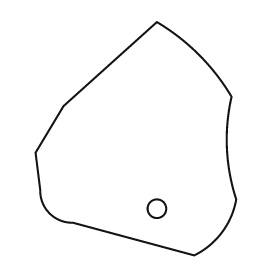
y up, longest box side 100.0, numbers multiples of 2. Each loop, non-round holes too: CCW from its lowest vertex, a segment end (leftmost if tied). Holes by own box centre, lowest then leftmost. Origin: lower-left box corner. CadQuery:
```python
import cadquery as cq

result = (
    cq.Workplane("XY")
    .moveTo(68.0, 0.0)
    .threePointArc((80.0, 10.0), (86.0, 24.0))
    .threePointArc((82.0, 46.0), (84.0, 68.0))
    .threePointArc((70.0, 86.0), (52.0, 100.0))
    .lineTo(12.0, 64.0)
    .lineTo(0.0, 44.0)
    .lineTo(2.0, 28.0)
    .threePointArc((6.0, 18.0), (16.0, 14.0))
    .close()
    .moveTo(52.0, 20.0)
    .circle(4.0)
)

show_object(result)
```